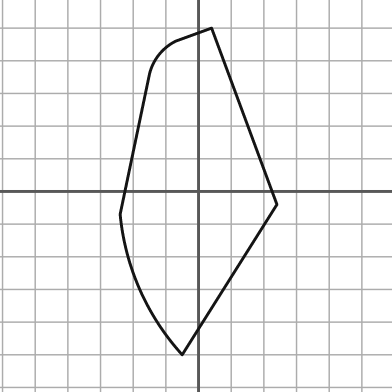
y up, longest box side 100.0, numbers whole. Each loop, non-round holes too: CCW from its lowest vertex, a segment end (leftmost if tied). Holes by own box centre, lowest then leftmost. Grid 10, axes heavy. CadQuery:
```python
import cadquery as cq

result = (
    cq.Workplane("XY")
    .moveTo(-5.0, -50.0)
    .lineTo(24.0, -4.0)
    .lineTo(4.0, 50.0)
    .lineTo(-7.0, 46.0)
    .threePointArc((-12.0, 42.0), (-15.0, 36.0))
    .lineTo(-24.0, -7.0)
    .threePointArc((-18.0, -30.0), (-5.0, -50.0))
    .close()
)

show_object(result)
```